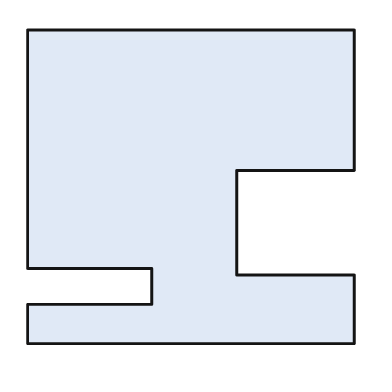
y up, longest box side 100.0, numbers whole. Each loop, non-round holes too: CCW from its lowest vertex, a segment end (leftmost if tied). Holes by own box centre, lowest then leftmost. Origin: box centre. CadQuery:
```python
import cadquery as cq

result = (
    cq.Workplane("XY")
    .moveTo(-50.0, -48.0)
    .lineTo(50.0, -48.0)
    .lineTo(50.0, -27.0)
    .lineTo(14.0, -27.0)
    .lineTo(14.0, 5.0)
    .lineTo(50.0, 5.0)
    .lineTo(50.0, 48.0)
    .lineTo(-50.0, 48.0)
    .lineTo(-50.0, -25.0)
    .lineTo(-12.0, -25.0)
    .lineTo(-12.0, -36.0)
    .lineTo(-50.0, -36.0)
    .close()
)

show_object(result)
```